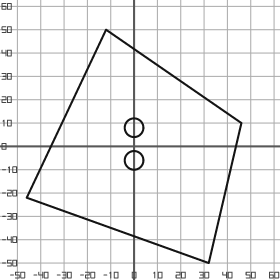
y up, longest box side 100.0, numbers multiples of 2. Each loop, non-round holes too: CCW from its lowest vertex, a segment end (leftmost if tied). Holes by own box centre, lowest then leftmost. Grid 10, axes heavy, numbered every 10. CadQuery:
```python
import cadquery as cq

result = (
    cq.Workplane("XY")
    .moveTo(32.0, -50.0)
    .lineTo(46.0, 10.0)
    .lineTo(-12.0, 50.0)
    .lineTo(-46.0, -22.0)
    .close()
    .moveTo(0.0, -6.0)
    .circle(4.0)
    .moveTo(0.0, 8.0)
    .circle(4.0)
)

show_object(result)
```